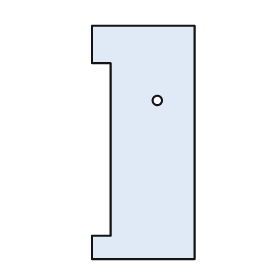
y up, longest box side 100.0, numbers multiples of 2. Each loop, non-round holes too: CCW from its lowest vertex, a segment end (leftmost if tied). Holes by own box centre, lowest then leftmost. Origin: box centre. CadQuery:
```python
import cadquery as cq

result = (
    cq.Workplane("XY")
    .moveTo(-22.0, -50.0)
    .lineTo(22.0, -50.0)
    .lineTo(22.0, 50.0)
    .lineTo(-22.0, 50.0)
    .lineTo(-22.0, 34.0)
    .lineTo(-14.0, 34.0)
    .lineTo(-14.0, -40.0)
    .lineTo(-22.0, -40.0)
    .close()
    .moveTo(6.0, 18.0)
    .circle(2.0)
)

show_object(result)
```